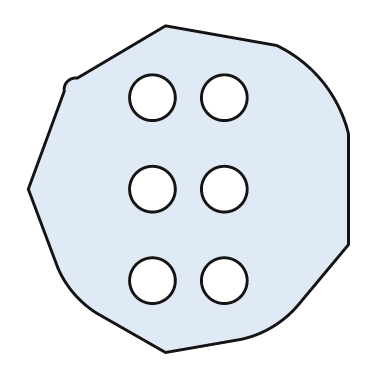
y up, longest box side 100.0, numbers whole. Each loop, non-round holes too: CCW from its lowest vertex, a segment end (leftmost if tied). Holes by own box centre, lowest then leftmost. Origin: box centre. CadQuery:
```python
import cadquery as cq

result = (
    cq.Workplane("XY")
    .moveTo(-7.0, -50.0)
    .lineTo(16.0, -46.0)
    .threePointArc((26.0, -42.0), (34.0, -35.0))
    .lineTo(49.0, -17.0)
    .lineTo(49.0, 17.0)
    .threePointArc((41.0, 33.0), (27.0, 44.0))
    .lineTo(-7.0, 50.0)
    .lineTo(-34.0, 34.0)
    .threePointArc((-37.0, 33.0), (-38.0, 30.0))
    .lineTo(-49.0, 0.0)
    .lineTo(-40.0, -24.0)
    .threePointArc((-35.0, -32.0), (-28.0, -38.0))
    .close()
    .moveTo(-11.0, -28.0)
    .circle(7.0)
    .moveTo(11.0, -28.0)
    .circle(7.0)
    .moveTo(-11.0, 0.0)
    .circle(7.0)
    .moveTo(11.0, 0.0)
    .circle(7.0)
    .moveTo(-11.0, 28.0)
    .circle(7.0)
    .moveTo(11.0, 28.0)
    .circle(7.0)
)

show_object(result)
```